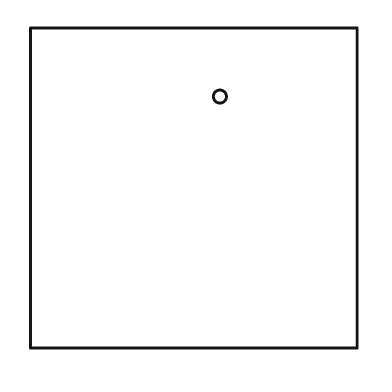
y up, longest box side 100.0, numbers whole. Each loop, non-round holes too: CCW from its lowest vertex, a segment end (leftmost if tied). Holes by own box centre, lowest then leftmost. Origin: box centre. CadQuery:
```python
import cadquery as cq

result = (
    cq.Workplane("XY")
    .moveTo(-50.0, -49.0)
    .lineTo(50.0, -49.0)
    .lineTo(50.0, 49.0)
    .lineTo(-50.0, 49.0)
    .close()
    .moveTo(8.0, 28.0)
    .circle(2.0)
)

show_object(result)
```